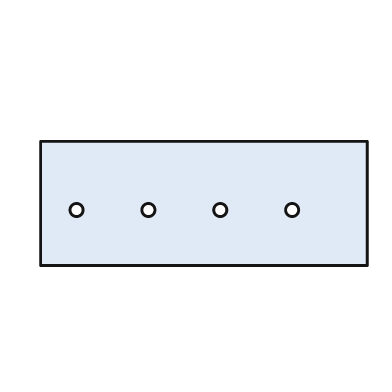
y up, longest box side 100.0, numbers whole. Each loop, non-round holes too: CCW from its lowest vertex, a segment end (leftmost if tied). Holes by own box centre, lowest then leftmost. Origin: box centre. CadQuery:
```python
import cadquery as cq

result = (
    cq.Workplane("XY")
    .moveTo(-50.0, -19.0)
    .lineTo(50.0, -19.0)
    .lineTo(50.0, 19.0)
    .lineTo(-50.0, 19.0)
    .close()
    .moveTo(-39.0, -2.0)
    .circle(2.0)
    .moveTo(-17.0, -2.0)
    .circle(2.0)
    .moveTo(5.0, -2.0)
    .circle(2.0)
    .moveTo(27.0, -2.0)
    .circle(2.0)
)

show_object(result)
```